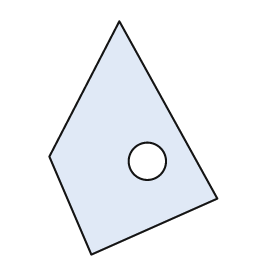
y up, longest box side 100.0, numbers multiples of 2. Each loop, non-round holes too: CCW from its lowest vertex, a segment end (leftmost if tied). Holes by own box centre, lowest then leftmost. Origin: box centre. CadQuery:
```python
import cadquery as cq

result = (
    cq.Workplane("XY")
    .moveTo(-18.0, -50.0)
    .lineTo(36.0, -26.0)
    .lineTo(-6.0, 50.0)
    .lineTo(-36.0, -8.0)
    .close()
    .moveTo(6.0, -10.0)
    .circle(8.0)
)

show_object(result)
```